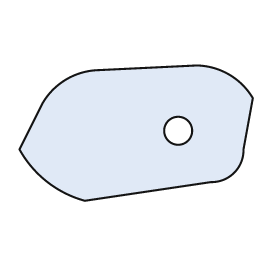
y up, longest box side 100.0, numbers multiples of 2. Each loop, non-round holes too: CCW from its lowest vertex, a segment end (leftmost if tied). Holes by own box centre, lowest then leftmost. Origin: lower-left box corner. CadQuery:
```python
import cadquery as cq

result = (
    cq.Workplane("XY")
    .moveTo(28.0, 0.0)
    .lineTo(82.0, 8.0)
    .threePointArc((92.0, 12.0), (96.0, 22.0))
    .lineTo(100.0, 44.0)
    .threePointArc((90.0, 54.0), (76.0, 58.0))
    .lineTo(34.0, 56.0)
    .threePointArc((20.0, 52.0), (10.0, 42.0))
    .lineTo(0.0, 22.0)
    .threePointArc((12.0, 8.0), (28.0, 0.0))
    .close()
    .moveTo(68.0, 30.0)
    .circle(6.0)
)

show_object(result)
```